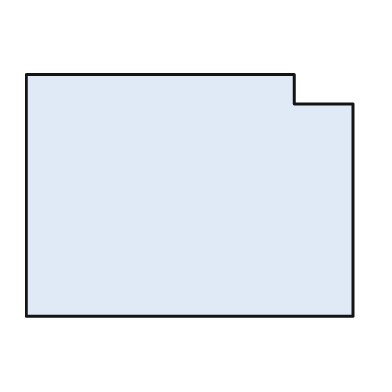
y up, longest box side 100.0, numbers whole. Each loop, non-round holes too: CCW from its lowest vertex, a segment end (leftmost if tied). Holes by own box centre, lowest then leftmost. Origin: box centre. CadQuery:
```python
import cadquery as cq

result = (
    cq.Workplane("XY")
    .moveTo(-50.0, -37.0)
    .lineTo(50.0, -37.0)
    .lineTo(50.0, 28.0)
    .lineTo(32.0, 28.0)
    .lineTo(32.0, 37.0)
    .lineTo(-50.0, 37.0)
    .close()
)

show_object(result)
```